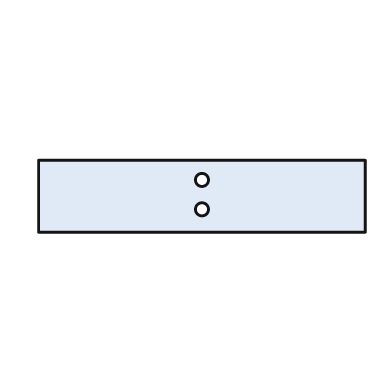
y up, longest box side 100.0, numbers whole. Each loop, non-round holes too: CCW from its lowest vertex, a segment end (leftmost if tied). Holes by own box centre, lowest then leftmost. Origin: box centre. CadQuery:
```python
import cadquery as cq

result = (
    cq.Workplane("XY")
    .moveTo(-50.0, -11.0)
    .lineTo(50.0, -11.0)
    .lineTo(50.0, 11.0)
    .lineTo(-50.0, 11.0)
    .close()
    .moveTo(0.0, -4.0)
    .circle(2.0)
    .moveTo(0.0, 5.0)
    .circle(2.0)
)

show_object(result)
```